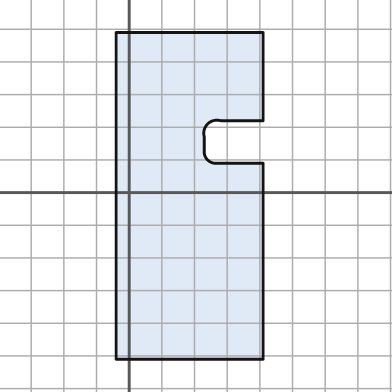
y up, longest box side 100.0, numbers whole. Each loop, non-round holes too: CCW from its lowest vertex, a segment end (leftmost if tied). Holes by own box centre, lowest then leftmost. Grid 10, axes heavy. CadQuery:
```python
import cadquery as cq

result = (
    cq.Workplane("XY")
    .moveTo(-4.0, -51.0)
    .lineTo(41.0, -51.0)
    .lineTo(41.0, 9.0)
    .lineTo(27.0, 9.0)
    .threePointArc((24.0, 10.0), (23.0, 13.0))
    .lineTo(23.0, 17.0)
    .threePointArc((24.0, 21.0), (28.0, 22.0))
    .lineTo(41.0, 22.0)
    .lineTo(41.0, 49.0)
    .lineTo(-4.0, 49.0)
    .close()
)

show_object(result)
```